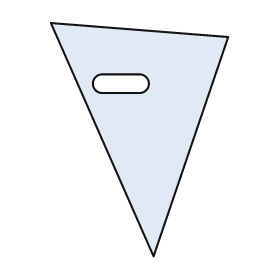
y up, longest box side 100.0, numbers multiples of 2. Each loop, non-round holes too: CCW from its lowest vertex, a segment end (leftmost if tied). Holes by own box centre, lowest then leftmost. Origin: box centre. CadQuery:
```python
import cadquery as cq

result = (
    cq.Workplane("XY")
    .moveTo(6.0, -50.0)
    .lineTo(38.0, 44.0)
    .lineTo(-38.0, 50.0)
    .close()
    .moveTo(-16.0, 20.0)
    .lineTo(0.0, 20.0)
    .threePointArc((4.0, 24.0), (0.0, 28.0))
    .lineTo(-16.0, 28.0)
    .threePointArc((-20.0, 24.0), (-16.0, 20.0))
    .close()
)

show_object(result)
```